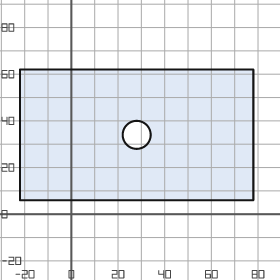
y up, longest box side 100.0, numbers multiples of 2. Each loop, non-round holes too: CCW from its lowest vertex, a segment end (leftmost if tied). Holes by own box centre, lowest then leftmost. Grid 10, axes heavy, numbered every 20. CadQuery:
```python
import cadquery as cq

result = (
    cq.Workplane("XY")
    .moveTo(-22.0, 6.0)
    .lineTo(78.0, 6.0)
    .lineTo(78.0, 62.0)
    .lineTo(-22.0, 62.0)
    .close()
    .moveTo(28.0, 34.0)
    .circle(6.0)
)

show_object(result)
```